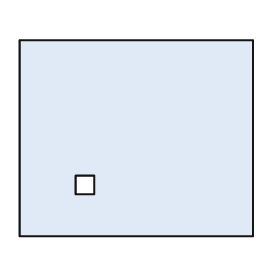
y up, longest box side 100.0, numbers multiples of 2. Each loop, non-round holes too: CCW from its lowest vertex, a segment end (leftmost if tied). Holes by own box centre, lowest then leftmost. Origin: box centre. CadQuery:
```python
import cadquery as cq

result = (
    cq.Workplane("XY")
    .moveTo(-50.0, -42.0)
    .lineTo(50.0, -42.0)
    .lineTo(50.0, 42.0)
    .lineTo(-50.0, 42.0)
    .close()
    .moveTo(-26.0, -24.0)
    .lineTo(-18.0, -24.0)
    .lineTo(-18.0, -16.0)
    .lineTo(-26.0, -16.0)
    .close()
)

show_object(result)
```